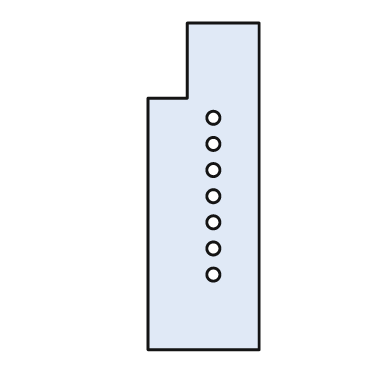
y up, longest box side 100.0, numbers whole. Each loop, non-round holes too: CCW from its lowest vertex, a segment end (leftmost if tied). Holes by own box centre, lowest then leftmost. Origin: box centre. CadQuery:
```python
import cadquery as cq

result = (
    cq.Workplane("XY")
    .moveTo(-17.0, -50.0)
    .lineTo(17.0, -50.0)
    .lineTo(17.0, 50.0)
    .lineTo(-5.0, 50.0)
    .lineTo(-5.0, 27.0)
    .lineTo(-17.0, 27.0)
    .close()
    .moveTo(3.0, -27.0)
    .circle(2.0)
    .moveTo(3.0, -19.0)
    .circle(2.0)
    .moveTo(3.0, -11.0)
    .circle(2.0)
    .moveTo(3.0, -3.0)
    .circle(2.0)
    .moveTo(3.0, 5.0)
    .circle(2.0)
    .moveTo(3.0, 13.0)
    .circle(2.0)
    .moveTo(3.0, 21.0)
    .circle(2.0)
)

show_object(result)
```